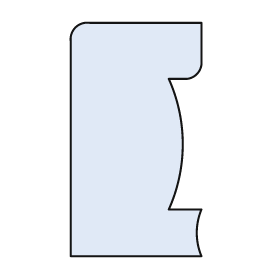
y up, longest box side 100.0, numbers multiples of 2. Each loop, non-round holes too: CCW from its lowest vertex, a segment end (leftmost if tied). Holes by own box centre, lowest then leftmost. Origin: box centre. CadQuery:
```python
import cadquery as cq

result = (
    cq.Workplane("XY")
    .moveTo(-28.0, -50.0)
    .lineTo(28.0, -50.0)
    .threePointArc((26.0, -40.0), (28.0, -30.0))
    .lineTo(14.0, -30.0)
    .threePointArc((20.0, -2.0), (14.0, 26.0))
    .lineTo(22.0, 26.0)
    .threePointArc((26.0, 28.0), (28.0, 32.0))
    .lineTo(28.0, 50.0)
    .lineTo(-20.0, 50.0)
    .threePointArc((-26.0, 48.0), (-28.0, 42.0))
    .close()
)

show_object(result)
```